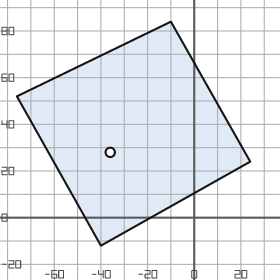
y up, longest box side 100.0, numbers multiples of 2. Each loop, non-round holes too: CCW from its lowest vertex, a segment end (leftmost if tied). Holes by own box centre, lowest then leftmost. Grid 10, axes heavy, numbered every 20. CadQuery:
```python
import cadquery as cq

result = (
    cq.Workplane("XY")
    .moveTo(-40.0, -12.0)
    .lineTo(24.0, 24.0)
    .lineTo(-10.0, 84.0)
    .lineTo(-76.0, 52.0)
    .close()
    .moveTo(-36.0, 28.0)
    .circle(2.0)
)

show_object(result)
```